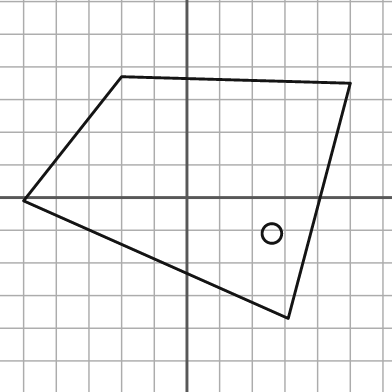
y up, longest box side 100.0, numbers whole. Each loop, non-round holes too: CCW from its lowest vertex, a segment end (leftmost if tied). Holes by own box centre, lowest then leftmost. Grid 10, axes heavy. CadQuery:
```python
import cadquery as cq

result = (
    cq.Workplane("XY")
    .moveTo(31.0, -37.0)
    .lineTo(50.0, 35.0)
    .lineTo(-20.0, 37.0)
    .lineTo(-50.0, -1.0)
    .close()
    .moveTo(26.0, -11.0)
    .circle(3.0)
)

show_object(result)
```